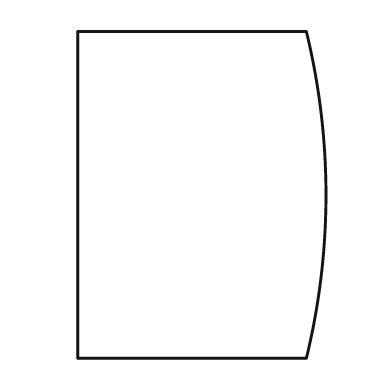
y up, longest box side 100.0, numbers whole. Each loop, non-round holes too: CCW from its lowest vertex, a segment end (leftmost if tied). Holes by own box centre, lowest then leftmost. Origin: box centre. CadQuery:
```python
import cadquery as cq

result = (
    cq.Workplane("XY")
    .moveTo(-38.0, -50.0)
    .lineTo(32.0, -50.0)
    .threePointArc((38.0, 0.0), (32.0, 50.0))
    .lineTo(-38.0, 50.0)
    .close()
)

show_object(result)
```